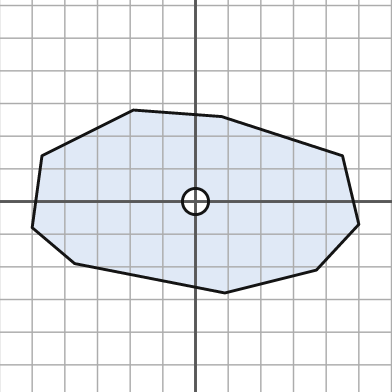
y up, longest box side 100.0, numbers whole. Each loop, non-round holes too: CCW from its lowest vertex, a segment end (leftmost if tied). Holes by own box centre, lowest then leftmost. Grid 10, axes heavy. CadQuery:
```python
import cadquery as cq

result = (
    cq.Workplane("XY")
    .moveTo(9.0, -28.0)
    .lineTo(37.0, -21.0)
    .lineTo(50.0, -7.0)
    .lineTo(45.0, 14.0)
    .lineTo(8.0, 26.0)
    .lineTo(-19.0, 28.0)
    .lineTo(-47.0, 14.0)
    .lineTo(-50.0, -8.0)
    .lineTo(-37.0, -19.0)
    .close()
    .moveTo(0.0, 0.0)
    .circle(4.0)
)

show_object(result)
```